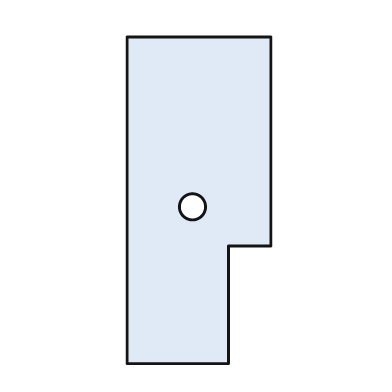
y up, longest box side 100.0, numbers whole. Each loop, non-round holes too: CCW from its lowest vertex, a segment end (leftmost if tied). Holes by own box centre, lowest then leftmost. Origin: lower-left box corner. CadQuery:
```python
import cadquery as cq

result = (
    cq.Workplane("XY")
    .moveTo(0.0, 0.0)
    .lineTo(31.0, 0.0)
    .lineTo(31.0, 36.0)
    .lineTo(44.0, 36.0)
    .lineTo(44.0, 100.0)
    .lineTo(0.0, 100.0)
    .close()
    .moveTo(20.0, 48.0)
    .circle(4.0)
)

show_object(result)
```